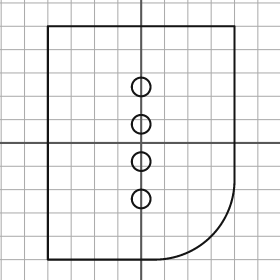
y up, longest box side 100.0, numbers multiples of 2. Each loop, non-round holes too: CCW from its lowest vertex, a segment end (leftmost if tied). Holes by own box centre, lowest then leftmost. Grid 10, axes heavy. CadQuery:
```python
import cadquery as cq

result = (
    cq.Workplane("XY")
    .moveTo(-40.0, -50.0)
    .lineTo(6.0, -50.0)
    .threePointArc((30.0, -40.0), (40.0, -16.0))
    .lineTo(40.0, 50.0)
    .lineTo(-40.0, 50.0)
    .close()
    .moveTo(0.0, -24.0)
    .circle(4.0)
    .moveTo(0.0, -8.0)
    .circle(4.0)
    .moveTo(0.0, 8.0)
    .circle(4.0)
    .moveTo(0.0, 24.0)
    .circle(4.0)
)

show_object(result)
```